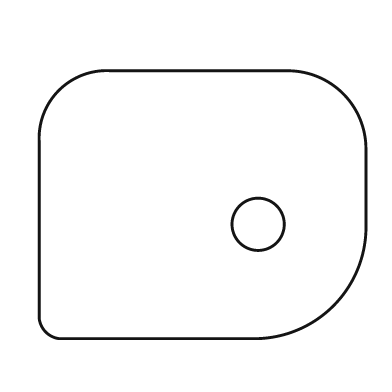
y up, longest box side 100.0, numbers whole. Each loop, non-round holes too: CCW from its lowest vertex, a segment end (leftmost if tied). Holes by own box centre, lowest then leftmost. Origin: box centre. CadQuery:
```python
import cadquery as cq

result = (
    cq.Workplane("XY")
    .moveTo(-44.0, -41.0)
    .lineTo(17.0, -41.0)
    .threePointArc((40.0, -31.0), (50.0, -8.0))
    .lineTo(50.0, 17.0)
    .threePointArc((43.0, 34.0), (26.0, 41.0))
    .lineTo(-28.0, 41.0)
    .threePointArc((-44.0, 35.0), (-50.0, 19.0))
    .lineTo(-50.0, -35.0)
    .threePointArc((-48.0, -39.0), (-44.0, -41.0))
    .close()
    .moveTo(17.0, -6.0)
    .circle(8.0)
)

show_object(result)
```